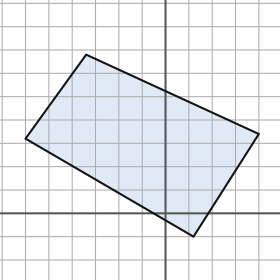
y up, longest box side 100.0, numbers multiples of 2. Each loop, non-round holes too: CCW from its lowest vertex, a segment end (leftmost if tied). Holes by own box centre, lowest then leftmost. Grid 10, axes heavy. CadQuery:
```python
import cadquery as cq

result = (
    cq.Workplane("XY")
    .moveTo(12.0, -10.0)
    .lineTo(40.0, 34.0)
    .lineTo(-34.0, 68.0)
    .lineTo(-60.0, 32.0)
    .close()
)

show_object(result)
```